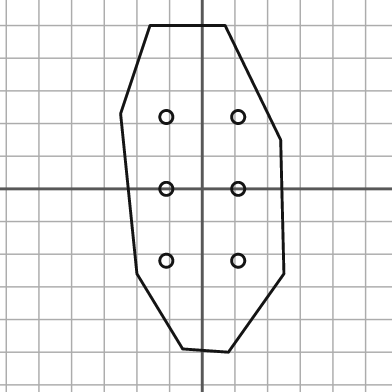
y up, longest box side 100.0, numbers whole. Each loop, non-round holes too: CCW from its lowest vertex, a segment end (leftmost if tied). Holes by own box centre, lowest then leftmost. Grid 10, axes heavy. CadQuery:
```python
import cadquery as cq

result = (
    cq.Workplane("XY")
    .moveTo(8.0, -50.0)
    .lineTo(25.0, -26.0)
    .lineTo(24.0, 15.0)
    .lineTo(7.0, 50.0)
    .lineTo(-16.0, 50.0)
    .lineTo(-25.0, 23.0)
    .lineTo(-20.0, -26.0)
    .lineTo(-6.0, -49.0)
    .close()
    .moveTo(-11.0, -22.0)
    .circle(2.0)
    .moveTo(11.0, -22.0)
    .circle(2.0)
    .moveTo(-11.0, 0.0)
    .circle(2.0)
    .moveTo(11.0, 0.0)
    .circle(2.0)
    .moveTo(-11.0, 22.0)
    .circle(2.0)
    .moveTo(11.0, 22.0)
    .circle(2.0)
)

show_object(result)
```